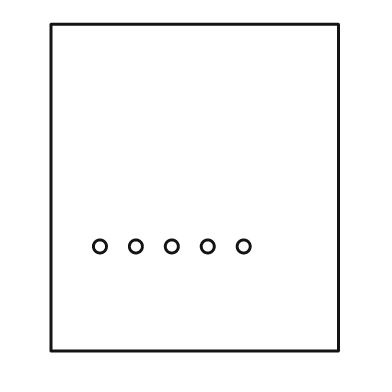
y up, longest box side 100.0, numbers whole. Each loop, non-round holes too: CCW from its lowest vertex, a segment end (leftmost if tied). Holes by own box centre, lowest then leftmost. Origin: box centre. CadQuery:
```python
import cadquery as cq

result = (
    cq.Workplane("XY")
    .moveTo(-44.0, -50.0)
    .lineTo(44.0, -50.0)
    .lineTo(44.0, 50.0)
    .lineTo(-44.0, 50.0)
    .close()
    .moveTo(-29.0, -18.0)
    .circle(2.0)
    .moveTo(-18.0, -18.0)
    .circle(2.0)
    .moveTo(-7.0, -18.0)
    .circle(2.0)
    .moveTo(4.0, -18.0)
    .circle(2.0)
    .moveTo(15.0, -18.0)
    .circle(2.0)
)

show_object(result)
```